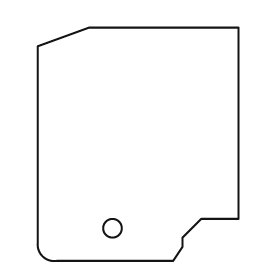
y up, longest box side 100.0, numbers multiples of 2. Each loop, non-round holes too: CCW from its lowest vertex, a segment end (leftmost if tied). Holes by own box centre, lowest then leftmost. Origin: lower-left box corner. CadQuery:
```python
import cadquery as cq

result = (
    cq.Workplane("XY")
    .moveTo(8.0, 0.0)
    .lineTo(58.0, 0.0)
    .lineTo(62.0, 6.0)
    .lineTo(62.0, 10.0)
    .lineTo(70.0, 18.0)
    .lineTo(86.0, 18.0)
    .lineTo(86.0, 100.0)
    .lineTo(22.0, 100.0)
    .lineTo(0.0, 92.0)
    .lineTo(0.0, 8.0)
    .threePointArc((2.0, 2.0), (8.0, 0.0))
    .close()
    .moveTo(32.0, 14.0)
    .circle(4.0)
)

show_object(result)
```